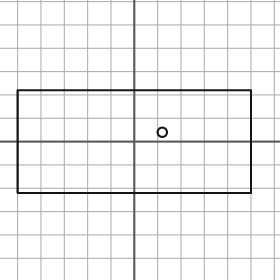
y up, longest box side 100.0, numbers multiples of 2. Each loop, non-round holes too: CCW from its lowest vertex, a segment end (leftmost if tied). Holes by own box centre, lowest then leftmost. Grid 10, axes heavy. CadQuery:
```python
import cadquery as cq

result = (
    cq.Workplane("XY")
    .moveTo(-50.0, -22.0)
    .lineTo(50.0, -22.0)
    .lineTo(50.0, 22.0)
    .lineTo(-50.0, 22.0)
    .close()
    .moveTo(12.0, 4.0)
    .circle(2.0)
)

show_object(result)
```